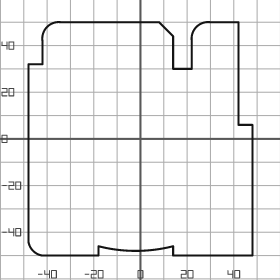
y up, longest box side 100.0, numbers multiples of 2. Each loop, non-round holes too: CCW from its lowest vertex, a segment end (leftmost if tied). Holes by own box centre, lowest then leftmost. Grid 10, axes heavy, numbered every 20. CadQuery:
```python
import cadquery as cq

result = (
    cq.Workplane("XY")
    .moveTo(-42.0, -50.0)
    .lineTo(-18.0, -50.0)
    .lineTo(-18.0, -46.0)
    .threePointArc((-2.0, -48.0), (14.0, -46.0))
    .lineTo(14.0, -50.0)
    .lineTo(48.0, -50.0)
    .lineTo(48.0, 6.0)
    .lineTo(42.0, 6.0)
    .lineTo(42.0, 50.0)
    .lineTo(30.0, 50.0)
    .threePointArc((24.0, 48.0), (22.0, 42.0))
    .lineTo(22.0, 30.0)
    .lineTo(14.0, 30.0)
    .lineTo(14.0, 44.0)
    .lineTo(8.0, 50.0)
    .lineTo(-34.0, 50.0)
    .threePointArc((-40.0, 48.0), (-42.0, 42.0))
    .lineTo(-42.0, 32.0)
    .lineTo(-48.0, 32.0)
    .lineTo(-48.0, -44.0)
    .threePointArc((-46.0, -48.0), (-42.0, -50.0))
    .close()
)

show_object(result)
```